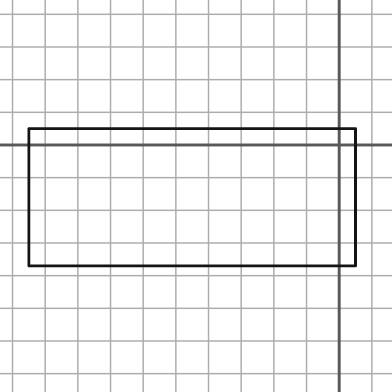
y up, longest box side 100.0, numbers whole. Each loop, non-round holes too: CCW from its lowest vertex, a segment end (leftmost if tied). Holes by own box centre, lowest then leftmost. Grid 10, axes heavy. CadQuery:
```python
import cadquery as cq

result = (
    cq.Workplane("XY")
    .moveTo(-95.0, -37.0)
    .lineTo(5.0, -37.0)
    .lineTo(5.0, 5.0)
    .lineTo(-95.0, 5.0)
    .close()
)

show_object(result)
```